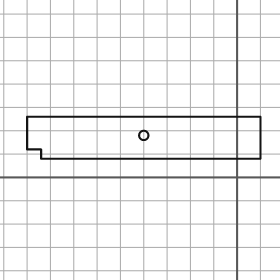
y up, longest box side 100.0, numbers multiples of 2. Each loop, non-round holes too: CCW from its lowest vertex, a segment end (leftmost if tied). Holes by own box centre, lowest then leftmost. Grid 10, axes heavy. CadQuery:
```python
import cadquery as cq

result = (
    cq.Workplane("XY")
    .moveTo(-84.0, 8.0)
    .lineTo(10.0, 8.0)
    .lineTo(10.0, 26.0)
    .lineTo(-90.0, 26.0)
    .lineTo(-90.0, 12.0)
    .lineTo(-84.0, 12.0)
    .close()
    .moveTo(-40.0, 18.0)
    .circle(2.0)
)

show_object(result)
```